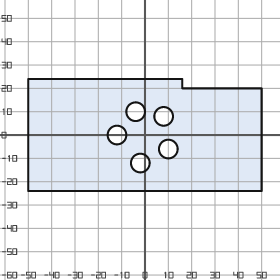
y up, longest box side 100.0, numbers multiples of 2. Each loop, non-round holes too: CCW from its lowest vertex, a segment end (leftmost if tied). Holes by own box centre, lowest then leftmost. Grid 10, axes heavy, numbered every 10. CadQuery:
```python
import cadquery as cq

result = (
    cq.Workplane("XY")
    .moveTo(-50.0, -24.0)
    .lineTo(50.0, -24.0)
    .lineTo(50.0, 20.0)
    .lineTo(16.0, 20.0)
    .lineTo(16.0, 24.0)
    .lineTo(-50.0, 24.0)
    .close()
    .moveTo(-2.0, -12.0)
    .circle(4.0)
    .moveTo(10.0, -6.0)
    .circle(4.0)
    .moveTo(-12.0, 0.0)
    .circle(4.0)
    .moveTo(8.0, 8.0)
    .circle(4.0)
    .moveTo(-4.0, 10.0)
    .circle(4.0)
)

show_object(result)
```